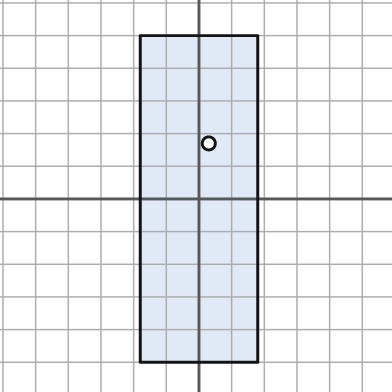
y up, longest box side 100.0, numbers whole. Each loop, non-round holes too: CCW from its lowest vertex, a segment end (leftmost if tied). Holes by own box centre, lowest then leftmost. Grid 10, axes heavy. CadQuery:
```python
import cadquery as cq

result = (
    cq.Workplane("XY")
    .moveTo(-18.0, -50.0)
    .lineTo(18.0, -50.0)
    .lineTo(18.0, 50.0)
    .lineTo(-18.0, 50.0)
    .close()
    .moveTo(3.0, 17.0)
    .circle(2.0)
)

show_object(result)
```